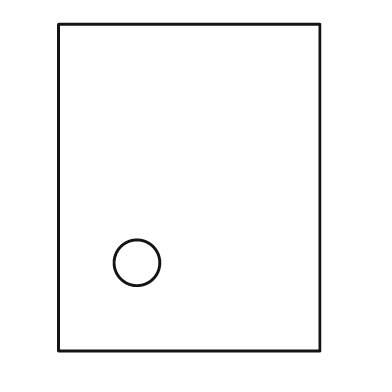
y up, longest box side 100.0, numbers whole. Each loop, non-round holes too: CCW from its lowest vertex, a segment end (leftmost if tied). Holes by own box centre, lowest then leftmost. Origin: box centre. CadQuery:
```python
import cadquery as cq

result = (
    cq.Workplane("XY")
    .moveTo(-40.0, -50.0)
    .lineTo(40.0, -50.0)
    .lineTo(40.0, 50.0)
    .lineTo(-40.0, 50.0)
    .close()
    .moveTo(-16.0, -23.0)
    .circle(7.0)
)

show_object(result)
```